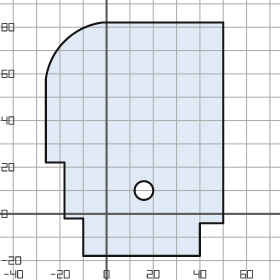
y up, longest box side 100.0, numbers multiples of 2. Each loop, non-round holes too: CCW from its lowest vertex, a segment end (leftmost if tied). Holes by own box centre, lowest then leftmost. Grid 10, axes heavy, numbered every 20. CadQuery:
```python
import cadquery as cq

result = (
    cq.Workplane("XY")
    .moveTo(-10.0, -18.0)
    .lineTo(40.0, -18.0)
    .lineTo(40.0, -4.0)
    .lineTo(50.0, -4.0)
    .lineTo(50.0, 82.0)
    .lineTo(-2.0, 82.0)
    .threePointArc((-18.0, 74.0), (-26.0, 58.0))
    .lineTo(-26.0, 22.0)
    .lineTo(-18.0, 22.0)
    .lineTo(-18.0, -2.0)
    .lineTo(-10.0, -2.0)
    .close()
    .moveTo(16.0, 10.0)
    .circle(4.0)
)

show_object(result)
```